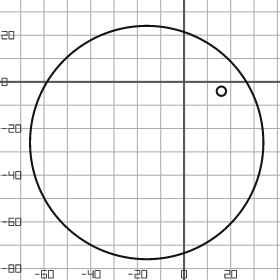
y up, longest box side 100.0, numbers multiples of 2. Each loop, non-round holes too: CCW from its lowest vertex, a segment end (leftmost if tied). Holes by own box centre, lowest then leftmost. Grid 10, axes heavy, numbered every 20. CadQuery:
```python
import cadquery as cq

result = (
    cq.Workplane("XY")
    .moveTo(-16.0, -26.0)
    .circle(50.0)
    .moveTo(16.0, -4.0)
    .circle(2.0)
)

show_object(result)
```